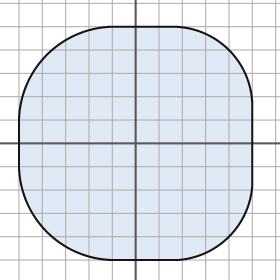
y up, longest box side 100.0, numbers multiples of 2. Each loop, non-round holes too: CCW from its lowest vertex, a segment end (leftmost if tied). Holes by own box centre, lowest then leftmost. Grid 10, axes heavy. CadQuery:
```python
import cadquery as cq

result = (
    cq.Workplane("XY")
    .moveTo(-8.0, -50.0)
    .lineTo(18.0, -50.0)
    .threePointArc((40.0, -40.0), (50.0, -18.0))
    .lineTo(50.0, 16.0)
    .threePointArc((40.0, 40.0), (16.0, 50.0))
    .lineTo(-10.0, 50.0)
    .threePointArc((-38.0, 38.0), (-50.0, 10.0))
    .lineTo(-50.0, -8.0)
    .threePointArc((-38.0, -38.0), (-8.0, -50.0))
    .close()
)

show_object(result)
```